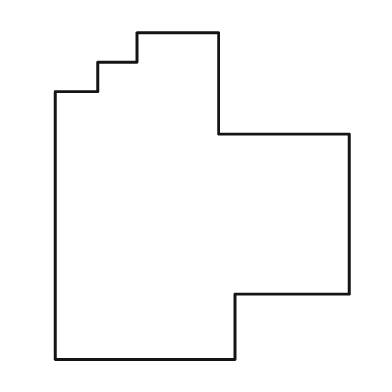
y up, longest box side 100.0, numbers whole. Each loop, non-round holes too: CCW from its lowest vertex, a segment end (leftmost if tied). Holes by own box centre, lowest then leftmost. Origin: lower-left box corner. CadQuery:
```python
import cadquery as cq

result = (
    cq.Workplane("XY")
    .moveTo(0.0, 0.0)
    .lineTo(55.0, 0.0)
    .lineTo(55.0, 20.0)
    .lineTo(90.0, 20.0)
    .lineTo(90.0, 69.0)
    .lineTo(50.0, 69.0)
    .lineTo(50.0, 100.0)
    .lineTo(25.0, 100.0)
    .lineTo(25.0, 91.0)
    .lineTo(13.0, 91.0)
    .lineTo(13.0, 82.0)
    .lineTo(0.0, 82.0)
    .close()
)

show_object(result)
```